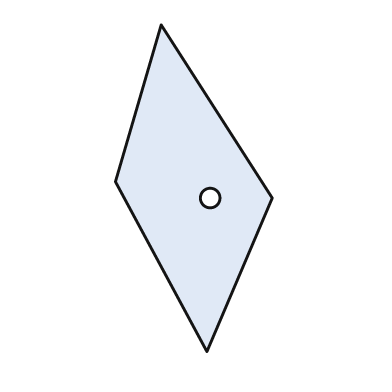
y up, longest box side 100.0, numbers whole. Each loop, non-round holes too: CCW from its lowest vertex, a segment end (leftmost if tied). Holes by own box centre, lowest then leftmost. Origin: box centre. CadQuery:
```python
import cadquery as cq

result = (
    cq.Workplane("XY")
    .moveTo(4.0, -50.0)
    .lineTo(24.0, -3.0)
    .lineTo(-10.0, 50.0)
    .lineTo(-24.0, 2.0)
    .close()
    .moveTo(5.0, -3.0)
    .circle(3.0)
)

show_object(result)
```